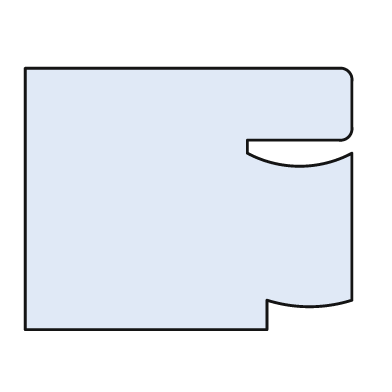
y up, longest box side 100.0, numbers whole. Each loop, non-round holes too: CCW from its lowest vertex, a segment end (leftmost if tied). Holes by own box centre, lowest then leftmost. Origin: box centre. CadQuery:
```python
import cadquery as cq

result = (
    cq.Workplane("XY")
    .moveTo(-50.0, -40.0)
    .lineTo(24.0, -40.0)
    .lineTo(24.0, -31.0)
    .threePointArc((37.0, -33.0), (50.0, -31.0))
    .lineTo(50.0, 14.0)
    .threePointArc((34.0, 10.0), (18.0, 14.0))
    .lineTo(18.0, 18.0)
    .lineTo(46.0, 18.0)
    .threePointArc((49.0, 19.0), (50.0, 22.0))
    .lineTo(50.0, 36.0)
    .threePointArc((49.0, 39.0), (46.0, 40.0))
    .lineTo(-50.0, 40.0)
    .close()
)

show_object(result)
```